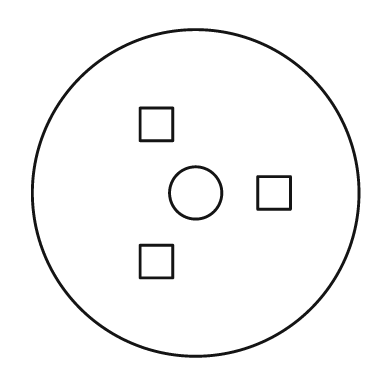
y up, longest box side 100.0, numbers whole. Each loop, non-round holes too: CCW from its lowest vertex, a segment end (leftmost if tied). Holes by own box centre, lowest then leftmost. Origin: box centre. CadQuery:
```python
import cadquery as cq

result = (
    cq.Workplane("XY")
    .moveTo(0.0, 0.0)
    .circle(50.0)
    .moveTo(-17.0, -26.0)
    .lineTo(-7.0, -26.0)
    .lineTo(-7.0, -16.0)
    .lineTo(-17.0, -16.0)
    .close()
    .moveTo(0.0, 0.0)
    .circle(8.0)
    .moveTo(19.0, -5.0)
    .lineTo(29.0, -5.0)
    .lineTo(29.0, 5.0)
    .lineTo(19.0, 5.0)
    .close()
    .moveTo(-17.0, 16.0)
    .lineTo(-7.0, 16.0)
    .lineTo(-7.0, 26.0)
    .lineTo(-17.0, 26.0)
    .close()
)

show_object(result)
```